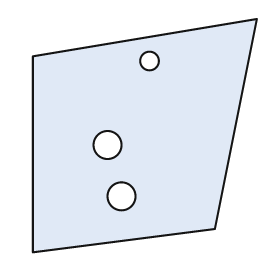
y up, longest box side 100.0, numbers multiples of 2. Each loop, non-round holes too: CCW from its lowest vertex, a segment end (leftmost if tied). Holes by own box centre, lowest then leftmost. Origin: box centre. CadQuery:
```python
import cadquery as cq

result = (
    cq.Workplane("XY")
    .moveTo(-48.0, -50.0)
    .lineTo(30.0, -40.0)
    .lineTo(48.0, 50.0)
    .lineTo(-48.0, 34.0)
    .close()
    .moveTo(-10.0, -26.0)
    .circle(6.0)
    .moveTo(-16.0, -4.0)
    .circle(6.0)
    .moveTo(2.0, 32.0)
    .circle(4.0)
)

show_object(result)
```